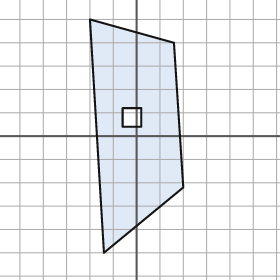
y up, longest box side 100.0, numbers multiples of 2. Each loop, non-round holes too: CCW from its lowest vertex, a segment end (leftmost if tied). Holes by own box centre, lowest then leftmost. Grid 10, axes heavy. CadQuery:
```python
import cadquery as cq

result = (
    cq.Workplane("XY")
    .moveTo(-14.0, -50.0)
    .lineTo(20.0, -22.0)
    .lineTo(16.0, 40.0)
    .lineTo(-20.0, 50.0)
    .close()
    .moveTo(-6.0, 4.0)
    .lineTo(2.0, 4.0)
    .lineTo(2.0, 12.0)
    .lineTo(-6.0, 12.0)
    .close()
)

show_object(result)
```